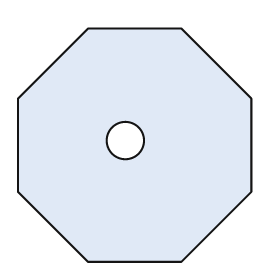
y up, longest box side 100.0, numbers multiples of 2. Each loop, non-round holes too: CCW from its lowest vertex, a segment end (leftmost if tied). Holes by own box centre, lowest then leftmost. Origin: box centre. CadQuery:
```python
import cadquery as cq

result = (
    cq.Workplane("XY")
    .moveTo(-20.0, -50.0)
    .lineTo(20.0, -50.0)
    .lineTo(50.0, -20.0)
    .lineTo(50.0, 20.0)
    .lineTo(20.0, 50.0)
    .lineTo(-20.0, 50.0)
    .lineTo(-50.0, 20.0)
    .lineTo(-50.0, -20.0)
    .close()
    .moveTo(-4.0, 2.0)
    .circle(8.0)
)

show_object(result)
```